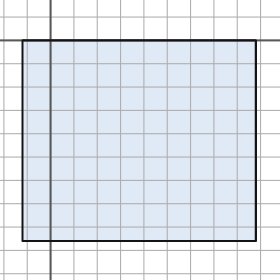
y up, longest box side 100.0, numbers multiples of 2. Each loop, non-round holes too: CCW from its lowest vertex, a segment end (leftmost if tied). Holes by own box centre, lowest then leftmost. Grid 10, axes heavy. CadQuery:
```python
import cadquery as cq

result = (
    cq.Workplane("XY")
    .moveTo(-12.0, -86.0)
    .lineTo(88.0, -86.0)
    .lineTo(88.0, 0.0)
    .lineTo(-12.0, 0.0)
    .close()
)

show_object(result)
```